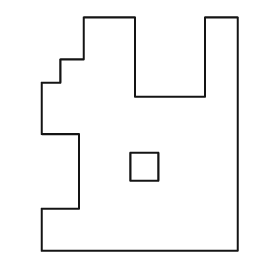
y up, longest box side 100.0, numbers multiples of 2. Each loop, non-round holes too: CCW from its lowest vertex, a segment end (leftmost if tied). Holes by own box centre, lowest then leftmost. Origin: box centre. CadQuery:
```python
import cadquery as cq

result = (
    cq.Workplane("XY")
    .moveTo(-42.0, -50.0)
    .lineTo(42.0, -50.0)
    .lineTo(42.0, 50.0)
    .lineTo(28.0, 50.0)
    .lineTo(28.0, 16.0)
    .lineTo(-2.0, 16.0)
    .lineTo(-2.0, 50.0)
    .lineTo(-24.0, 50.0)
    .lineTo(-24.0, 32.0)
    .lineTo(-34.0, 32.0)
    .lineTo(-34.0, 22.0)
    .lineTo(-42.0, 22.0)
    .lineTo(-42.0, 0.0)
    .lineTo(-26.0, 0.0)
    .lineTo(-26.0, -32.0)
    .lineTo(-42.0, -32.0)
    .close()
    .moveTo(-4.0, -20.0)
    .lineTo(8.0, -20.0)
    .lineTo(8.0, -8.0)
    .lineTo(-4.0, -8.0)
    .close()
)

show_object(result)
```